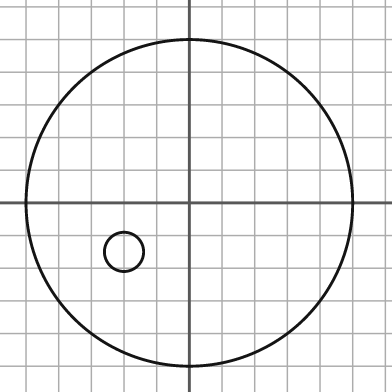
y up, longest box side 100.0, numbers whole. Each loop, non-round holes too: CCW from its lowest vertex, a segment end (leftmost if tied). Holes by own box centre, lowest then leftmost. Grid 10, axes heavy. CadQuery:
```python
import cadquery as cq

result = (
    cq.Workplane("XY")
    .moveTo(0.0, 0.0)
    .circle(50.0)
    .moveTo(-20.0, -15.0)
    .circle(6.0)
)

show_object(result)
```